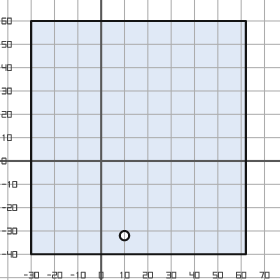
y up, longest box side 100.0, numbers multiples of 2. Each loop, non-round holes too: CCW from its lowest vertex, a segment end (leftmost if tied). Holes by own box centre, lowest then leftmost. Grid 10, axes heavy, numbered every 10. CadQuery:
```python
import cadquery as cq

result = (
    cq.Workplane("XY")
    .moveTo(-30.0, -40.0)
    .lineTo(62.0, -40.0)
    .lineTo(62.0, 60.0)
    .lineTo(-30.0, 60.0)
    .close()
    .moveTo(10.0, -32.0)
    .circle(2.0)
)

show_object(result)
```